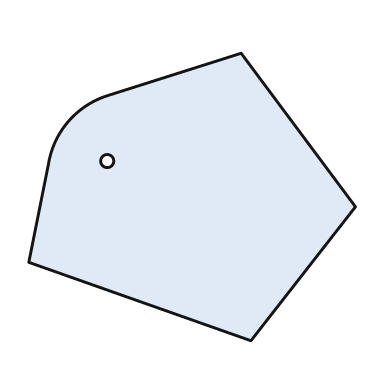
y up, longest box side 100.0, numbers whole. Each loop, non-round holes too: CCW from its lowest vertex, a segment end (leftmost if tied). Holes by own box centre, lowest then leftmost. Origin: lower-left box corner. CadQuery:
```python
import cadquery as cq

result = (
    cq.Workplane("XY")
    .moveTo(68.0, 0.0)
    .lineTo(100.0, 41.0)
    .lineTo(65.0, 88.0)
    .lineTo(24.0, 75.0)
    .threePointArc((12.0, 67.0), (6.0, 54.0))
    .lineTo(0.0, 24.0)
    .close()
    .moveTo(24.0, 55.0)
    .circle(2.0)
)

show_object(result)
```